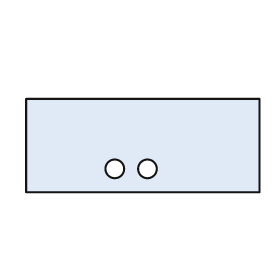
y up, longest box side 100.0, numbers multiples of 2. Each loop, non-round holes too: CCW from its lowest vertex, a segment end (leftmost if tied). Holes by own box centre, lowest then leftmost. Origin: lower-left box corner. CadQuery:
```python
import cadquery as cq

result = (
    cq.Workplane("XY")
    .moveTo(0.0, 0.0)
    .lineTo(100.0, 0.0)
    .lineTo(100.0, 40.0)
    .lineTo(0.0, 40.0)
    .close()
    .moveTo(38.0, 10.0)
    .circle(4.0)
    .moveTo(52.0, 10.0)
    .circle(4.0)
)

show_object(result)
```